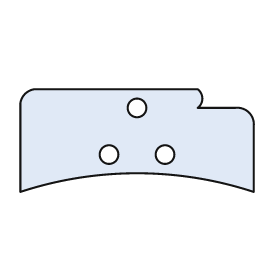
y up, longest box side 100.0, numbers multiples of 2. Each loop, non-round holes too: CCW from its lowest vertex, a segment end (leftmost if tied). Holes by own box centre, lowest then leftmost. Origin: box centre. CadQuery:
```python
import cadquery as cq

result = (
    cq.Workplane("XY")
    .moveTo(-50.0, -22.0)
    .threePointArc((0.0, -14.0), (50.0, -22.0))
    .lineTo(50.0, 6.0)
    .threePointArc((48.0, 12.0), (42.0, 14.0))
    .lineTo(26.0, 14.0)
    .threePointArc((28.0, 18.0), (26.0, 22.0))
    .lineTo(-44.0, 22.0)
    .threePointArc((-48.0, 20.0), (-50.0, 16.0))
    .close()
    .moveTo(-12.0, -6.0)
    .circle(4.0)
    .moveTo(12.0, -6.0)
    .circle(4.0)
    .moveTo(0.0, 14.0)
    .circle(4.0)
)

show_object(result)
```